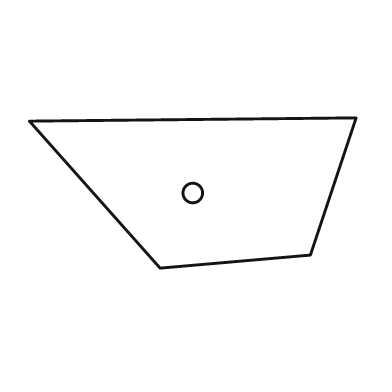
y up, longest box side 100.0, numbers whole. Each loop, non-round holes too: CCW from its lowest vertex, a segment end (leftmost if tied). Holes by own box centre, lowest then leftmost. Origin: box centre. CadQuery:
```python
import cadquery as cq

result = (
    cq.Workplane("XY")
    .moveTo(-10.0, -23.0)
    .lineTo(36.0, -19.0)
    .lineTo(50.0, 23.0)
    .lineTo(-50.0, 22.0)
    .close()
    .moveTo(0.0, 0.0)
    .circle(3.0)
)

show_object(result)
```